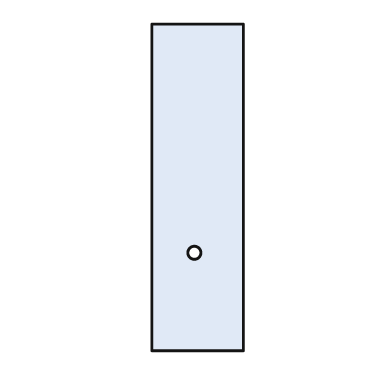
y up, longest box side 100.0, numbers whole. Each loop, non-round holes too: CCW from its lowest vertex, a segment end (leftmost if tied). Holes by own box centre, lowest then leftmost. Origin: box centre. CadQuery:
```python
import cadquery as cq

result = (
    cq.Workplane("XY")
    .moveTo(-14.0, -50.0)
    .lineTo(14.0, -50.0)
    .lineTo(14.0, 50.0)
    .lineTo(-14.0, 50.0)
    .close()
    .moveTo(-1.0, -20.0)
    .circle(2.0)
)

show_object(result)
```